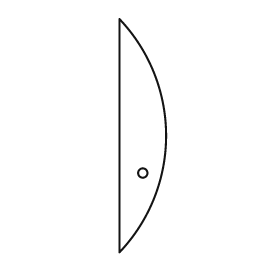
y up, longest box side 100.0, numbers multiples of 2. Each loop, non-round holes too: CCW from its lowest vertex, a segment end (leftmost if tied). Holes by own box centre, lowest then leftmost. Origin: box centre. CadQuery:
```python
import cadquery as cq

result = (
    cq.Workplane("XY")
    .moveTo(-10.0, -50.0)
    .threePointArc((10.0, 0.0), (-10.0, 50.0))
    .close()
    .moveTo(0.0, -16.0)
    .circle(2.0)
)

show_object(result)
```